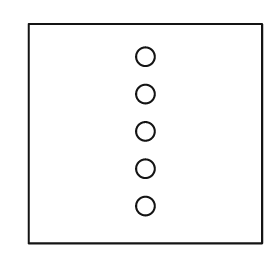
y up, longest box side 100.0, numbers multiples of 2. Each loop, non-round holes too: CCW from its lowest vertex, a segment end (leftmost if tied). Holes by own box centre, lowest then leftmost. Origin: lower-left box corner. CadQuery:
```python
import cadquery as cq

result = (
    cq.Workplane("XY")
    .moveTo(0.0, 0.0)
    .lineTo(100.0, 0.0)
    .lineTo(100.0, 94.0)
    .lineTo(0.0, 94.0)
    .close()
    .moveTo(50.0, 16.0)
    .circle(4.0)
    .moveTo(50.0, 32.0)
    .circle(4.0)
    .moveTo(50.0, 48.0)
    .circle(4.0)
    .moveTo(50.0, 64.0)
    .circle(4.0)
    .moveTo(50.0, 80.0)
    .circle(4.0)
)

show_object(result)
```